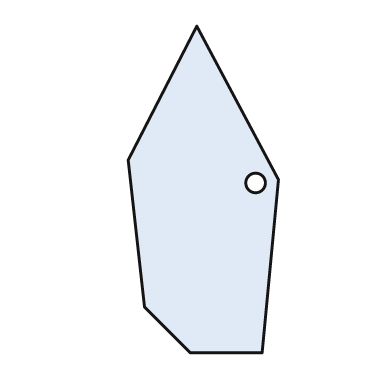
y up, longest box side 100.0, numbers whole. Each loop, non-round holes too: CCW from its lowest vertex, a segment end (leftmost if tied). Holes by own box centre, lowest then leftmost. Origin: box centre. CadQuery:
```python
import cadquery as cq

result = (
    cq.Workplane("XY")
    .moveTo(-4.0, -50.0)
    .lineTo(18.0, -50.0)
    .lineTo(23.0, 3.0)
    .lineTo(-2.0, 50.0)
    .lineTo(-23.0, 9.0)
    .lineTo(-18.0, -36.0)
    .close()
    .moveTo(16.0, 2.0)
    .circle(3.0)
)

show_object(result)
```